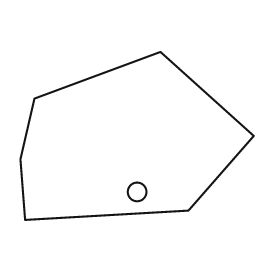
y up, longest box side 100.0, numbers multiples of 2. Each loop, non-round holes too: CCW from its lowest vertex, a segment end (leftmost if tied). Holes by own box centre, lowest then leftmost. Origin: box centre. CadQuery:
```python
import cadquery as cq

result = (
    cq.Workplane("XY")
    .moveTo(-48.0, -36.0)
    .lineTo(22.0, -32.0)
    .lineTo(50.0, 0.0)
    .lineTo(10.0, 36.0)
    .lineTo(-44.0, 16.0)
    .lineTo(-50.0, -10.0)
    .close()
    .moveTo(0.0, -24.0)
    .circle(4.0)
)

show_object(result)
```